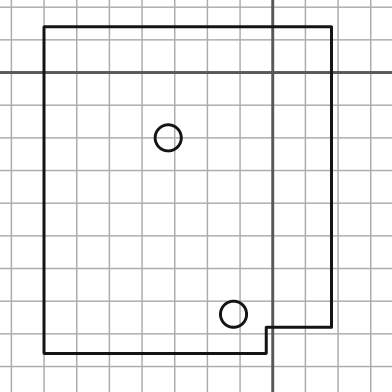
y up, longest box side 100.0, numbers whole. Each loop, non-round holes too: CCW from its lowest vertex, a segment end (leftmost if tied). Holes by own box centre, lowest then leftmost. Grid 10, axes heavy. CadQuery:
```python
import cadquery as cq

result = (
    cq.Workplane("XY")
    .moveTo(-70.0, -86.0)
    .lineTo(-2.0, -86.0)
    .lineTo(-2.0, -78.0)
    .lineTo(18.0, -78.0)
    .lineTo(18.0, 14.0)
    .lineTo(-70.0, 14.0)
    .close()
    .moveTo(-12.0, -74.0)
    .circle(4.0)
    .moveTo(-32.0, -20.0)
    .circle(4.0)
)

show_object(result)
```